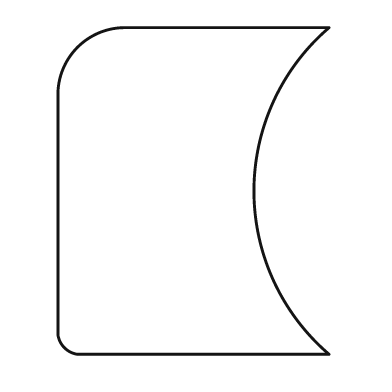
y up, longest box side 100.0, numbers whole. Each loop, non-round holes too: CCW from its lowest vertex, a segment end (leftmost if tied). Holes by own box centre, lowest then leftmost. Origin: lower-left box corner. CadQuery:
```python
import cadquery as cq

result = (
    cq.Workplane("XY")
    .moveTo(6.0, 0.0)
    .lineTo(83.0, 0.0)
    .threePointArc((60.0, 50.0), (83.0, 100.0))
    .lineTo(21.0, 100.0)
    .threePointArc((6.0, 94.0), (0.0, 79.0))
    .lineTo(0.0, 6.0)
    .threePointArc((2.0, 2.0), (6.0, 0.0))
    .close()
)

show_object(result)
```